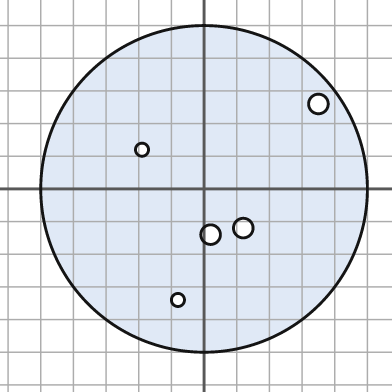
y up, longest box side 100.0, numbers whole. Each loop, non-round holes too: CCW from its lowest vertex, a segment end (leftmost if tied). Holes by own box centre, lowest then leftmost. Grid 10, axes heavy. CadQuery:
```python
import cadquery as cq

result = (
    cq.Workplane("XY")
    .moveTo(0.0, 0.0)
    .circle(50.0)
    .moveTo(-8.0, -34.0)
    .circle(2.0)
    .moveTo(2.0, -14.0)
    .circle(3.0)
    .moveTo(12.0, -12.0)
    .circle(3.0)
    .moveTo(-19.0, 12.0)
    .circle(2.0)
    .moveTo(35.0, 26.0)
    .circle(3.0)
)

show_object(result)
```